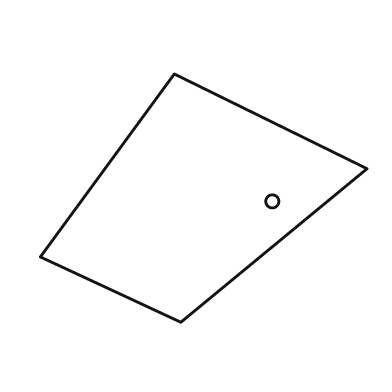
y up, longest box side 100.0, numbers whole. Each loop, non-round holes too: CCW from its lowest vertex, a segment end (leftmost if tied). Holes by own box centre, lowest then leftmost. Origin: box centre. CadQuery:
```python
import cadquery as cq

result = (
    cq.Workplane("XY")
    .moveTo(-7.0, -38.0)
    .lineTo(50.0, 9.0)
    .lineTo(-9.0, 38.0)
    .lineTo(-50.0, -18.0)
    .close()
    .moveTo(21.0, -1.0)
    .circle(2.0)
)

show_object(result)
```